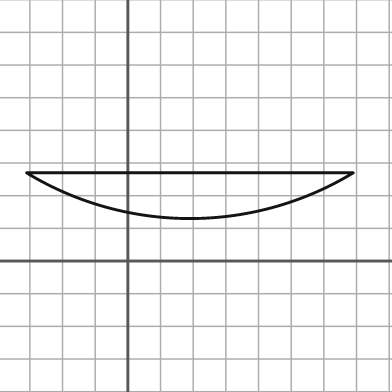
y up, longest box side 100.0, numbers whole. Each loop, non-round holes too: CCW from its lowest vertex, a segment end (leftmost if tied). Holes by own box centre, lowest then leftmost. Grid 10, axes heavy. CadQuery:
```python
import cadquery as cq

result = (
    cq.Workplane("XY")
    .moveTo(-31.0, 27.0)
    .threePointArc((19.0, 13.0), (69.0, 27.0))
    .close()
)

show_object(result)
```